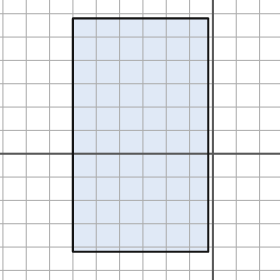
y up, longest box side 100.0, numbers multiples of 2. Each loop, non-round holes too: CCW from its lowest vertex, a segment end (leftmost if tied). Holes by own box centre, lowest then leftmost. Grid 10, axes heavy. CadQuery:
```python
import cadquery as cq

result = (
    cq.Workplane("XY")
    .moveTo(-60.0, -42.0)
    .lineTo(-2.0, -42.0)
    .lineTo(-2.0, 58.0)
    .lineTo(-60.0, 58.0)
    .close()
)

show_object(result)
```